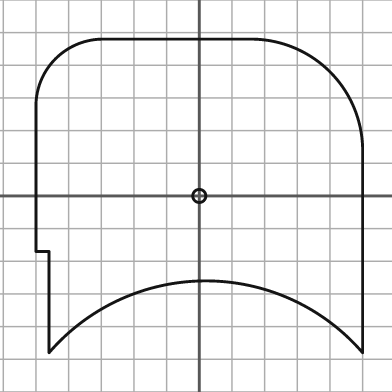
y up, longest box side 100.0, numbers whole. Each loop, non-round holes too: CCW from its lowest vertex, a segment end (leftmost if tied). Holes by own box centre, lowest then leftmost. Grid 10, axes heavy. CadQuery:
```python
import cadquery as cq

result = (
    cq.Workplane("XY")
    .moveTo(-46.0, -48.0)
    .threePointArc((2.0, -26.0), (50.0, -48.0))
    .lineTo(50.0, 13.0)
    .threePointArc((40.0, 38.0), (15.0, 48.0))
    .lineTo(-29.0, 48.0)
    .threePointArc((-44.0, 42.0), (-50.0, 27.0))
    .lineTo(-50.0, -17.0)
    .lineTo(-46.0, -17.0)
    .close()
    .moveTo(0.0, 0.0)
    .circle(2.0)
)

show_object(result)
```